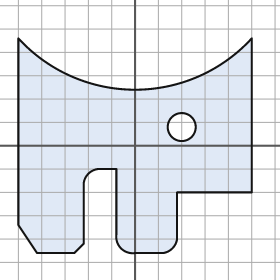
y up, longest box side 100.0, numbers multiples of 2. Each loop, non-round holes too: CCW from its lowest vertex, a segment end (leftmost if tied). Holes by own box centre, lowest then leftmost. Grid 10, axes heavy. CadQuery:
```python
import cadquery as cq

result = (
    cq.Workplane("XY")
    .moveTo(-42.0, -46.0)
    .lineTo(-26.0, -46.0)
    .lineTo(-22.0, -42.0)
    .lineTo(-22.0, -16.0)
    .threePointArc((-20.0, -12.0), (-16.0, -10.0))
    .lineTo(-8.0, -10.0)
    .lineTo(-8.0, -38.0)
    .threePointArc((-6.0, -44.0), (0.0, -46.0))
    .lineTo(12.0, -46.0)
    .threePointArc((16.0, -44.0), (18.0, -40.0))
    .lineTo(18.0, -20.0)
    .lineTo(50.0, -20.0)
    .lineTo(50.0, 46.0)
    .threePointArc((0.0, 24.0), (-50.0, 46.0))
    .lineTo(-50.0, -34.0)
    .close()
    .moveTo(20.0, 8.0)
    .circle(6.0)
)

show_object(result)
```